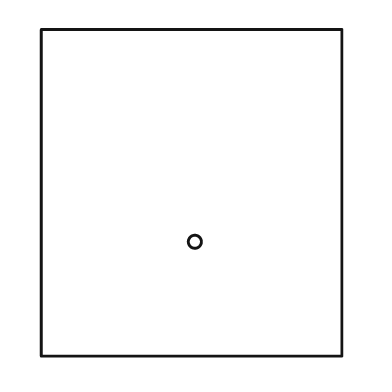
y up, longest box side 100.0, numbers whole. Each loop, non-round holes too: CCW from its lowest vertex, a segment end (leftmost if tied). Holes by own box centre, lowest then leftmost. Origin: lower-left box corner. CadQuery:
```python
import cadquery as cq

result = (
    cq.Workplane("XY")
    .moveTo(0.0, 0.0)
    .lineTo(92.0, 0.0)
    .lineTo(92.0, 100.0)
    .lineTo(0.0, 100.0)
    .close()
    .moveTo(47.0, 35.0)
    .circle(2.0)
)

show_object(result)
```